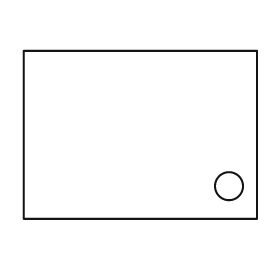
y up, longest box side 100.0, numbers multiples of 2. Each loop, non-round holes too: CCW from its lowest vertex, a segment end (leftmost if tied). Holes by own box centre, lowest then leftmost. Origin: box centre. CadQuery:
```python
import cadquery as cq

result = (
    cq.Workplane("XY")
    .moveTo(-50.0, -36.0)
    .lineTo(50.0, -36.0)
    .lineTo(50.0, 36.0)
    .lineTo(-50.0, 36.0)
    .close()
    .moveTo(38.0, -22.0)
    .circle(6.0)
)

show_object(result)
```